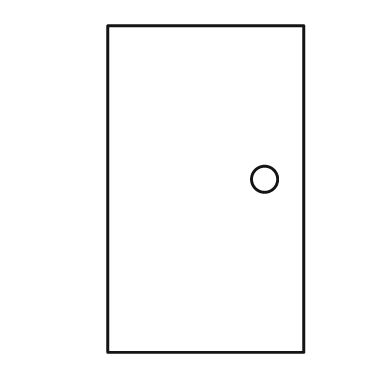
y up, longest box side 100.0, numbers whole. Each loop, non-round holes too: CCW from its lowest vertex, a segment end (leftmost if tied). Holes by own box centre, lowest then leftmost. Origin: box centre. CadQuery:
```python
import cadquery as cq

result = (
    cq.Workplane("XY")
    .moveTo(-30.0, -50.0)
    .lineTo(30.0, -50.0)
    .lineTo(30.0, 50.0)
    .lineTo(-30.0, 50.0)
    .close()
    .moveTo(18.0, 3.0)
    .circle(4.0)
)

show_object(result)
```